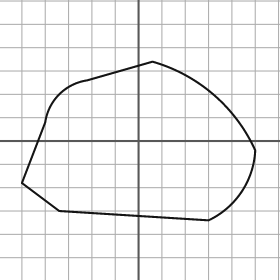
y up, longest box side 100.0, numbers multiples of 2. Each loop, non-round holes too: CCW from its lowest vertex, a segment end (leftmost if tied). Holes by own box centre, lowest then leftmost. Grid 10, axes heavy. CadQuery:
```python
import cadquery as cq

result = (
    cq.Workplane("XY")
    .moveTo(30.0, -34.0)
    .threePointArc((44.0, -22.0), (50.0, -4.0))
    .threePointArc((32.0, 20.0), (6.0, 34.0))
    .lineTo(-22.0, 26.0)
    .threePointArc((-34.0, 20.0), (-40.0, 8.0))
    .lineTo(-50.0, -18.0)
    .lineTo(-34.0, -30.0)
    .close()
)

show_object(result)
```